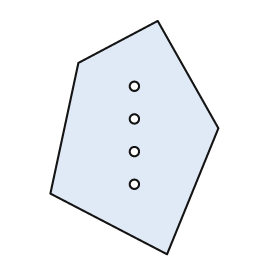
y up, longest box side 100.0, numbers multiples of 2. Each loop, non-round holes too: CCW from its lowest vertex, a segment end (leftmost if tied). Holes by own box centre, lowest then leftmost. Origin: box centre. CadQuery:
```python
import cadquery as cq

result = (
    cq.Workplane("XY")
    .moveTo(14.0, -50.0)
    .lineTo(36.0, 4.0)
    .lineTo(10.0, 50.0)
    .lineTo(-24.0, 32.0)
    .lineTo(-36.0, -24.0)
    .close()
    .moveTo(0.0, -20.0)
    .circle(2.0)
    .moveTo(0.0, -6.0)
    .circle(2.0)
    .moveTo(0.0, 8.0)
    .circle(2.0)
    .moveTo(0.0, 22.0)
    .circle(2.0)
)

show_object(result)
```